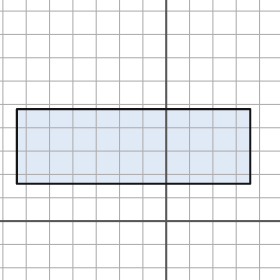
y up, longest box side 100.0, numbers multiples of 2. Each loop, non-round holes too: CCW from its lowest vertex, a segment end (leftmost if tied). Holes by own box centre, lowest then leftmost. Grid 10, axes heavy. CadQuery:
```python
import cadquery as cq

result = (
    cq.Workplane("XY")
    .moveTo(-64.0, 16.0)
    .lineTo(36.0, 16.0)
    .lineTo(36.0, 48.0)
    .lineTo(-64.0, 48.0)
    .close()
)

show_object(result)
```